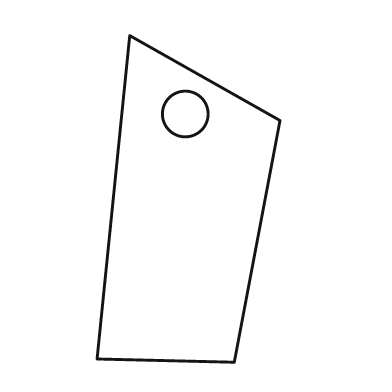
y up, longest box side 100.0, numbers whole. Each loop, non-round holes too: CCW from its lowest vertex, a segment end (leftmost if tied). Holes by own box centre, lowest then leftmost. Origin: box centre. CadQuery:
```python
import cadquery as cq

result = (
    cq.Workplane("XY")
    .moveTo(14.0, -50.0)
    .lineTo(28.0, 24.0)
    .lineTo(-18.0, 50.0)
    .lineTo(-28.0, -49.0)
    .close()
    .moveTo(-1.0, 26.0)
    .circle(7.0)
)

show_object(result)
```